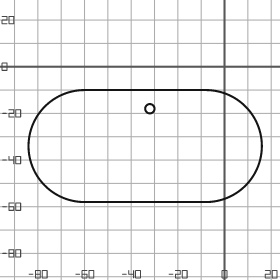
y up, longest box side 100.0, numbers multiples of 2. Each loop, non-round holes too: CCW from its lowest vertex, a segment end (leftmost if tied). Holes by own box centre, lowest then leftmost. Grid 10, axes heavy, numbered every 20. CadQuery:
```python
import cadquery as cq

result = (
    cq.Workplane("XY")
    .moveTo(-60.0, -58.0)
    .lineTo(-8.0, -58.0)
    .threePointArc((16.0, -34.0), (-8.0, -10.0))
    .lineTo(-60.0, -10.0)
    .threePointArc((-84.0, -34.0), (-60.0, -58.0))
    .close()
    .moveTo(-32.0, -18.0)
    .circle(2.0)
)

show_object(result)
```